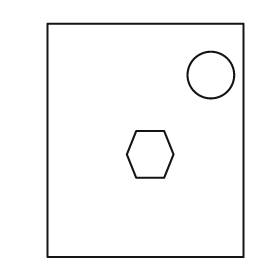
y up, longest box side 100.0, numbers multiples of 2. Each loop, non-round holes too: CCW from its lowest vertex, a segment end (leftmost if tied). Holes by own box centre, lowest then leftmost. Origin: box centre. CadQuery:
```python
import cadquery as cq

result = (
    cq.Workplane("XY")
    .moveTo(-42.0, -50.0)
    .lineTo(42.0, -50.0)
    .lineTo(42.0, 50.0)
    .lineTo(-42.0, 50.0)
    .close()
    .moveTo(-4.0, -16.0)
    .lineTo(8.0, -16.0)
    .lineTo(12.0, -6.0)
    .lineTo(8.0, 4.0)
    .lineTo(-4.0, 4.0)
    .lineTo(-8.0, -6.0)
    .close()
    .moveTo(28.0, 28.0)
    .circle(10.0)
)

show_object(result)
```